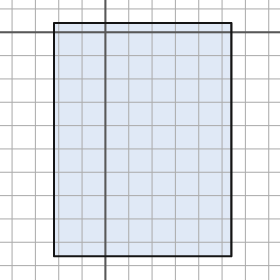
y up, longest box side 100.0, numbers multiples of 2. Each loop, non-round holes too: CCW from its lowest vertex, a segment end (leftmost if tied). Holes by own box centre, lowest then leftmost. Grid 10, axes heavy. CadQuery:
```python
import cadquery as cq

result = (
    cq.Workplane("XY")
    .moveTo(-22.0, -96.0)
    .lineTo(54.0, -96.0)
    .lineTo(54.0, 4.0)
    .lineTo(-22.0, 4.0)
    .close()
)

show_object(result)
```